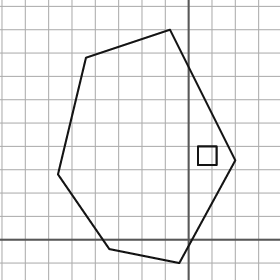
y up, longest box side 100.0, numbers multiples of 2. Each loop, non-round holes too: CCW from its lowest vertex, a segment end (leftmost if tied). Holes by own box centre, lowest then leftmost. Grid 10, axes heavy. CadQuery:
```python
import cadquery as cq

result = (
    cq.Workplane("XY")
    .moveTo(-4.0, -10.0)
    .lineTo(20.0, 34.0)
    .lineTo(-8.0, 90.0)
    .lineTo(-44.0, 78.0)
    .lineTo(-56.0, 28.0)
    .lineTo(-34.0, -4.0)
    .close()
    .moveTo(4.0, 32.0)
    .lineTo(12.0, 32.0)
    .lineTo(12.0, 40.0)
    .lineTo(4.0, 40.0)
    .close()
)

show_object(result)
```